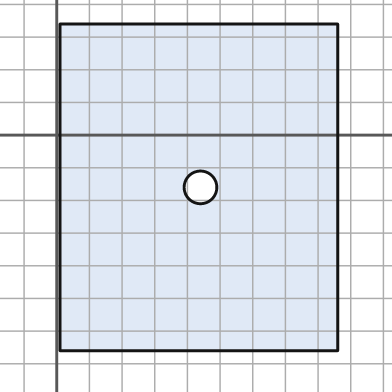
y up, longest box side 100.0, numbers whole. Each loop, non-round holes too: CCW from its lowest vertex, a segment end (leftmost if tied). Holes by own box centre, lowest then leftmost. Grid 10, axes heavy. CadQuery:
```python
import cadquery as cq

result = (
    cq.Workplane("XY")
    .moveTo(1.0, -66.0)
    .lineTo(86.0, -66.0)
    .lineTo(86.0, 34.0)
    .lineTo(1.0, 34.0)
    .close()
    .moveTo(44.0, -16.0)
    .circle(5.0)
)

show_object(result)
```